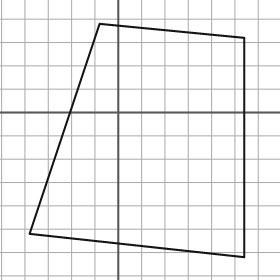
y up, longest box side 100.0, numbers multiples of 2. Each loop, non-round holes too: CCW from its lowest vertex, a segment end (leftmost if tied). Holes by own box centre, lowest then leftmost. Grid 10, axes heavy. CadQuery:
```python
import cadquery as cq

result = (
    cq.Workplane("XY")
    .moveTo(54.0, -62.0)
    .lineTo(54.0, 32.0)
    .lineTo(-8.0, 38.0)
    .lineTo(-38.0, -52.0)
    .close()
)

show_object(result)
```